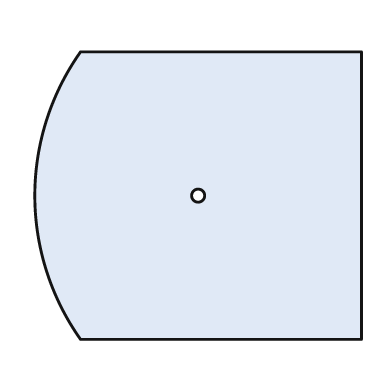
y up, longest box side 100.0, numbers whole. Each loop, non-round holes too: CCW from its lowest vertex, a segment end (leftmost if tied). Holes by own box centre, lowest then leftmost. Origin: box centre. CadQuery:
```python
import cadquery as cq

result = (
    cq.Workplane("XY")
    .moveTo(-36.0, -44.0)
    .lineTo(50.0, -44.0)
    .lineTo(50.0, 44.0)
    .lineTo(-36.0, 44.0)
    .threePointArc((-50.0, 0.0), (-36.0, -44.0))
    .close()
    .moveTo(0.0, 0.0)
    .circle(2.0)
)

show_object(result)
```